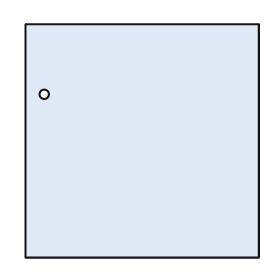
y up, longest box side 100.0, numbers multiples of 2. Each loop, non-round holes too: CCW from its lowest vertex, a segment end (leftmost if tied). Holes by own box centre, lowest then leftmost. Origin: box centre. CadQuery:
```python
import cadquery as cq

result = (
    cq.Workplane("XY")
    .moveTo(-50.0, -50.0)
    .lineTo(50.0, -50.0)
    .lineTo(50.0, 50.0)
    .lineTo(-50.0, 50.0)
    .close()
    .moveTo(-42.0, 20.0)
    .circle(2.0)
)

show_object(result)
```